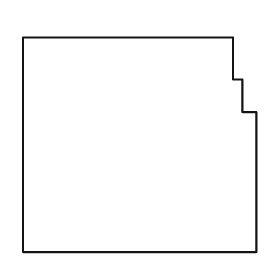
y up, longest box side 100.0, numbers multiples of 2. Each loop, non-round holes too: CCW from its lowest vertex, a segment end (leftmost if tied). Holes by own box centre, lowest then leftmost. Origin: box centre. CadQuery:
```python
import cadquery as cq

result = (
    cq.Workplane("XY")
    .moveTo(-50.0, -46.0)
    .lineTo(50.0, -46.0)
    .lineTo(50.0, 14.0)
    .lineTo(44.0, 14.0)
    .lineTo(44.0, 28.0)
    .lineTo(40.0, 28.0)
    .lineTo(40.0, 46.0)
    .lineTo(-50.0, 46.0)
    .close()
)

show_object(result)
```